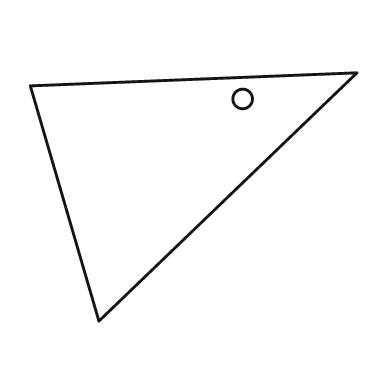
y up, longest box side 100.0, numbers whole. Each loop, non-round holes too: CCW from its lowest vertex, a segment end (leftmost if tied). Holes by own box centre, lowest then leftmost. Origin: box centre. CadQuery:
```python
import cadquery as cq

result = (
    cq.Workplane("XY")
    .moveTo(-29.0, -38.0)
    .lineTo(50.0, 38.0)
    .lineTo(-50.0, 34.0)
    .close()
    .moveTo(15.0, 30.0)
    .circle(3.0)
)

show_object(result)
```